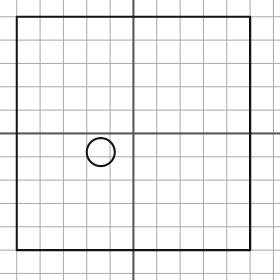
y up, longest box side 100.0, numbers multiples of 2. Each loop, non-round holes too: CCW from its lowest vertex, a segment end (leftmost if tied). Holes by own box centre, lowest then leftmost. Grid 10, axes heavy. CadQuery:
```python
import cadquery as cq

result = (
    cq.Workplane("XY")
    .moveTo(-50.0, -50.0)
    .lineTo(50.0, -50.0)
    .lineTo(50.0, 50.0)
    .lineTo(-50.0, 50.0)
    .close()
    .moveTo(-14.0, -8.0)
    .circle(6.0)
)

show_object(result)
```